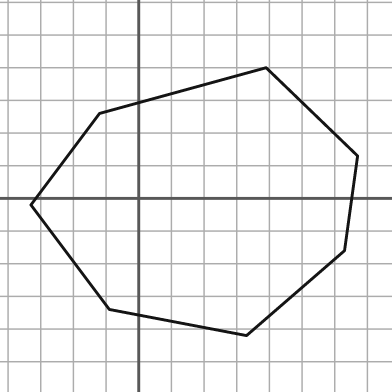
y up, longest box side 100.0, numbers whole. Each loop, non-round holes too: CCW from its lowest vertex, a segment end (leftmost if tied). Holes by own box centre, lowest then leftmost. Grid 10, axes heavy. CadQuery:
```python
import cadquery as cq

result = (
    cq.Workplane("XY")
    .moveTo(33.0, -42.0)
    .lineTo(63.0, -16.0)
    .lineTo(67.0, 13.0)
    .lineTo(39.0, 40.0)
    .lineTo(-12.0, 26.0)
    .lineTo(-33.0, -2.0)
    .lineTo(-9.0, -34.0)
    .close()
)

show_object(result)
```